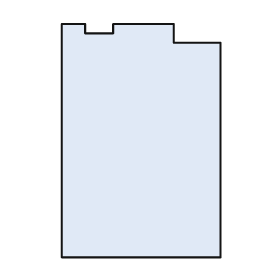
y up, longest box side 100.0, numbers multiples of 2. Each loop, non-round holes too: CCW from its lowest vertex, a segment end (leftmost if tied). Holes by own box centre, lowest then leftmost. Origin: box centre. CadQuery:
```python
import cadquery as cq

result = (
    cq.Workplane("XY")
    .moveTo(-34.0, -50.0)
    .lineTo(34.0, -50.0)
    .lineTo(34.0, 42.0)
    .lineTo(14.0, 42.0)
    .lineTo(14.0, 50.0)
    .lineTo(-12.0, 50.0)
    .lineTo(-12.0, 46.0)
    .lineTo(-24.0, 46.0)
    .lineTo(-24.0, 50.0)
    .lineTo(-34.0, 50.0)
    .close()
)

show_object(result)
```